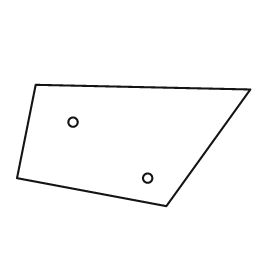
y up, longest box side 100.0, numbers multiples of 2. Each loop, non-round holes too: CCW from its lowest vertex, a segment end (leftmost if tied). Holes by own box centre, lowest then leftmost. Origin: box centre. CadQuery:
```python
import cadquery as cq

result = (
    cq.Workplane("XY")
    .moveTo(14.0, -26.0)
    .lineTo(50.0, 24.0)
    .lineTo(-42.0, 26.0)
    .lineTo(-50.0, -14.0)
    .close()
    .moveTo(6.0, -14.0)
    .circle(2.0)
    .moveTo(-26.0, 10.0)
    .circle(2.0)
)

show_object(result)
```